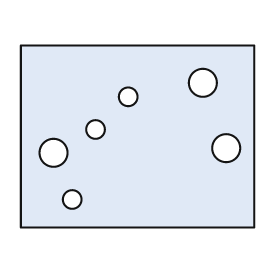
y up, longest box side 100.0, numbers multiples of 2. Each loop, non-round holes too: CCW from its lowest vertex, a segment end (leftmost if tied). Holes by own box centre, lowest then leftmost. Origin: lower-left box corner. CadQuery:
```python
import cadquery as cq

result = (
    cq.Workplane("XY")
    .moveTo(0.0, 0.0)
    .lineTo(100.0, 0.0)
    .lineTo(100.0, 78.0)
    .lineTo(0.0, 78.0)
    .close()
    .moveTo(22.0, 12.0)
    .circle(4.0)
    .moveTo(14.0, 32.0)
    .circle(6.0)
    .moveTo(88.0, 34.0)
    .circle(6.0)
    .moveTo(32.0, 42.0)
    .circle(4.0)
    .moveTo(46.0, 56.0)
    .circle(4.0)
    .moveTo(78.0, 62.0)
    .circle(6.0)
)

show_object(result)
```